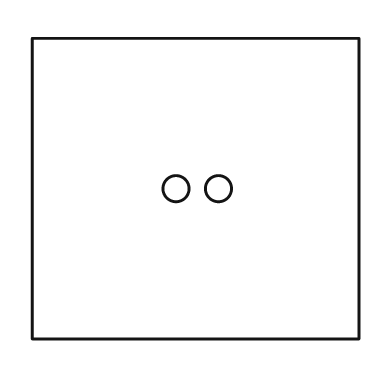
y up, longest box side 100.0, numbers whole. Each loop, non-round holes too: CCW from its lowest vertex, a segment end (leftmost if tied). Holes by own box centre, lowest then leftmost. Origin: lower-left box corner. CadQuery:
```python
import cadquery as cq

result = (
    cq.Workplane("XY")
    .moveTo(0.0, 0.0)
    .lineTo(100.0, 0.0)
    .lineTo(100.0, 92.0)
    .lineTo(0.0, 92.0)
    .close()
    .moveTo(44.0, 46.0)
    .circle(4.0)
    .moveTo(57.0, 46.0)
    .circle(4.0)
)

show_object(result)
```